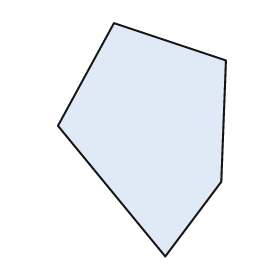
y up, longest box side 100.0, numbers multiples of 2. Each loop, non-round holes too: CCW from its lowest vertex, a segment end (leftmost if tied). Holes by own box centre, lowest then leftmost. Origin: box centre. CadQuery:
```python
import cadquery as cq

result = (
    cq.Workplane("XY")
    .moveTo(10.0, -50.0)
    .lineTo(34.0, -18.0)
    .lineTo(36.0, 34.0)
    .lineTo(-12.0, 50.0)
    .lineTo(-36.0, 6.0)
    .close()
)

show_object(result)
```